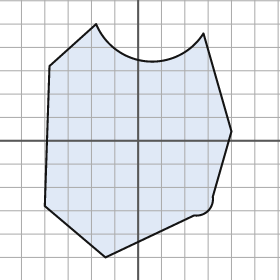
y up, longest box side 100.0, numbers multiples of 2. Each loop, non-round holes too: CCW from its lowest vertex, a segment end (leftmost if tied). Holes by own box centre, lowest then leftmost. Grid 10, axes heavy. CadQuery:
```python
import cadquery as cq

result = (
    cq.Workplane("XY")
    .moveTo(-14.0, -50.0)
    .lineTo(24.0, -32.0)
    .threePointArc((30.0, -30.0), (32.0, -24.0))
    .lineTo(40.0, 4.0)
    .lineTo(28.0, 46.0)
    .threePointArc((4.0, 34.0), (-18.0, 50.0))
    .lineTo(-38.0, 32.0)
    .lineTo(-40.0, -28.0)
    .close()
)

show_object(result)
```